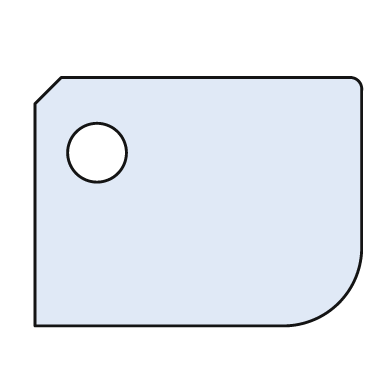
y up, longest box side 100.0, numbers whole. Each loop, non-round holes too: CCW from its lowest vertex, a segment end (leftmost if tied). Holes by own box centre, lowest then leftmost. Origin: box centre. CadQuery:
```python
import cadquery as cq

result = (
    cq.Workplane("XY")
    .moveTo(-50.0, -38.0)
    .lineTo(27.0, -38.0)
    .threePointArc((43.0, -31.0), (50.0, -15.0))
    .lineTo(50.0, 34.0)
    .threePointArc((49.0, 37.0), (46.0, 38.0))
    .lineTo(-42.0, 38.0)
    .lineTo(-50.0, 30.0)
    .close()
    .moveTo(-31.0, 15.0)
    .circle(9.0)
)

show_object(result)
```